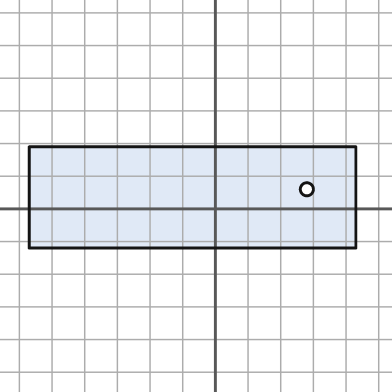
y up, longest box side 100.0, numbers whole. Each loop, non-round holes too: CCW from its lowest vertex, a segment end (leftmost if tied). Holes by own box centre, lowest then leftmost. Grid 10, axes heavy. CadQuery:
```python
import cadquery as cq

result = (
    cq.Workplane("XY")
    .moveTo(-57.0, -12.0)
    .lineTo(43.0, -12.0)
    .lineTo(43.0, 19.0)
    .lineTo(-57.0, 19.0)
    .close()
    .moveTo(28.0, 6.0)
    .circle(2.0)
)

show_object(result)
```